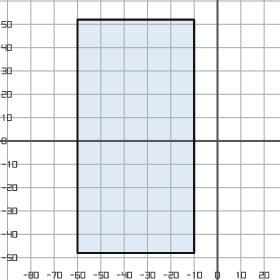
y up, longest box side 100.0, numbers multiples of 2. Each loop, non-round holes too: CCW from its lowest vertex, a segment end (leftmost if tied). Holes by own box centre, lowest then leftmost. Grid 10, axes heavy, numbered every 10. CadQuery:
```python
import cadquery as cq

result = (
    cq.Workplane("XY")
    .moveTo(-60.0, -48.0)
    .lineTo(-10.0, -48.0)
    .lineTo(-10.0, 52.0)
    .lineTo(-60.0, 52.0)
    .close()
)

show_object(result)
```